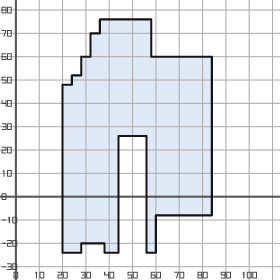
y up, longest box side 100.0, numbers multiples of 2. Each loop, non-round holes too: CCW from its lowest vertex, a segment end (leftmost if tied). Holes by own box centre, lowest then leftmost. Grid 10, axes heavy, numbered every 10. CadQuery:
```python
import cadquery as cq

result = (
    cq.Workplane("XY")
    .moveTo(20.0, -24.0)
    .lineTo(28.0, -24.0)
    .lineTo(28.0, -20.0)
    .lineTo(38.0, -20.0)
    .lineTo(38.0, -24.0)
    .lineTo(44.0, -24.0)
    .lineTo(44.0, 26.0)
    .lineTo(56.0, 26.0)
    .lineTo(56.0, -24.0)
    .lineTo(60.0, -24.0)
    .lineTo(60.0, -8.0)
    .lineTo(84.0, -8.0)
    .lineTo(84.0, 60.0)
    .lineTo(58.0, 60.0)
    .lineTo(58.0, 76.0)
    .lineTo(36.0, 76.0)
    .lineTo(36.0, 70.0)
    .lineTo(32.0, 70.0)
    .lineTo(32.0, 60.0)
    .lineTo(28.0, 60.0)
    .lineTo(28.0, 52.0)
    .lineTo(24.0, 52.0)
    .lineTo(24.0, 48.0)
    .lineTo(20.0, 48.0)
    .close()
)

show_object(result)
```